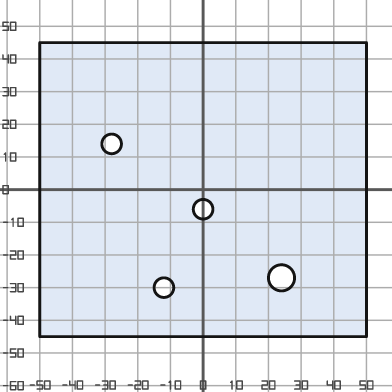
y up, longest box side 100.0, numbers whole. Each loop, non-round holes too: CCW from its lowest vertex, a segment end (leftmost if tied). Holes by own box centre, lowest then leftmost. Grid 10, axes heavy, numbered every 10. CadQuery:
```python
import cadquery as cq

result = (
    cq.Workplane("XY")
    .moveTo(-50.0, -45.0)
    .lineTo(50.0, -45.0)
    .lineTo(50.0, 45.0)
    .lineTo(-50.0, 45.0)
    .close()
    .moveTo(-12.0, -30.0)
    .circle(3.0)
    .moveTo(24.0, -27.0)
    .circle(4.0)
    .moveTo(0.0, -6.0)
    .circle(3.0)
    .moveTo(-28.0, 14.0)
    .circle(3.0)
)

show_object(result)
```